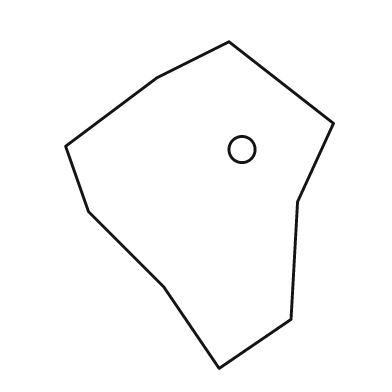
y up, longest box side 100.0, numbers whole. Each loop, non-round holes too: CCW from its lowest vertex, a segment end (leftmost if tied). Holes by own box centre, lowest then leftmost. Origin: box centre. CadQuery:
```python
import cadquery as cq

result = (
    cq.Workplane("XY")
    .moveTo(6.0, -50.0)
    .lineTo(28.0, -35.0)
    .lineTo(30.0, 1.0)
    .lineTo(41.0, 25.0)
    .lineTo(9.0, 50.0)
    .lineTo(-13.0, 39.0)
    .lineTo(-41.0, 18.0)
    .lineTo(-34.0, -2.0)
    .lineTo(-11.0, -25.0)
    .close()
    .moveTo(13.0, 17.0)
    .circle(4.0)
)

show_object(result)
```